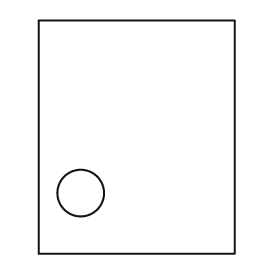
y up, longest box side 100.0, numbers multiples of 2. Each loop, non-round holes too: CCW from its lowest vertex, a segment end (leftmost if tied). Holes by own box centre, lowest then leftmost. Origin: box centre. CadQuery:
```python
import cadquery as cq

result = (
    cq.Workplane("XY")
    .moveTo(-42.0, -50.0)
    .lineTo(42.0, -50.0)
    .lineTo(42.0, 50.0)
    .lineTo(-42.0, 50.0)
    .close()
    .moveTo(-24.0, -24.0)
    .circle(10.0)
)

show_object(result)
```